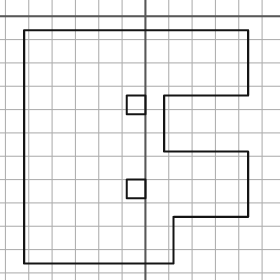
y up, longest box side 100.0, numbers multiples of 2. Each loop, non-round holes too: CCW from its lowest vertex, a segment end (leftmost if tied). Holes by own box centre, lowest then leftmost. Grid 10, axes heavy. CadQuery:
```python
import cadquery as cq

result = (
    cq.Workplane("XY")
    .moveTo(-52.0, -106.0)
    .lineTo(12.0, -106.0)
    .lineTo(12.0, -86.0)
    .lineTo(44.0, -86.0)
    .lineTo(44.0, -58.0)
    .lineTo(8.0, -58.0)
    .lineTo(8.0, -34.0)
    .lineTo(44.0, -34.0)
    .lineTo(44.0, -6.0)
    .lineTo(-52.0, -6.0)
    .close()
    .moveTo(-8.0, -78.0)
    .lineTo(0.0, -78.0)
    .lineTo(0.0, -70.0)
    .lineTo(-8.0, -70.0)
    .close()
    .moveTo(-8.0, -42.0)
    .lineTo(0.0, -42.0)
    .lineTo(0.0, -34.0)
    .lineTo(-8.0, -34.0)
    .close()
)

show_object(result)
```